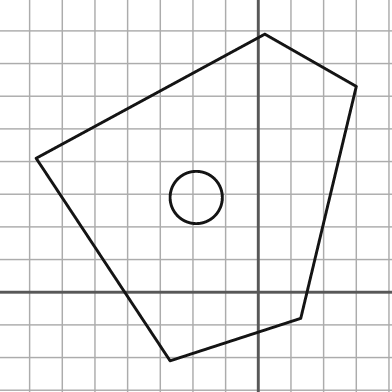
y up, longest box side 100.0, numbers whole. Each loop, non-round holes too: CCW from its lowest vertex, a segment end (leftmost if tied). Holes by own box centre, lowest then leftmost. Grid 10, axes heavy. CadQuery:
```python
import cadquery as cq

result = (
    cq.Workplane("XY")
    .moveTo(-27.0, -21.0)
    .lineTo(13.0, -8.0)
    .lineTo(30.0, 63.0)
    .lineTo(2.0, 79.0)
    .lineTo(-68.0, 41.0)
    .close()
    .moveTo(-19.0, 29.0)
    .circle(8.0)
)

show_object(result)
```